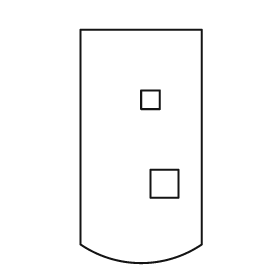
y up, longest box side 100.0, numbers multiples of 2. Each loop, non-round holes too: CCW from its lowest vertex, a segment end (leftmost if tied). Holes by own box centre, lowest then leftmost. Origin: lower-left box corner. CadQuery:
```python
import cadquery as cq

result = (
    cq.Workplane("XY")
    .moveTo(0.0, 8.0)
    .threePointArc((26.0, 0.0), (52.0, 8.0))
    .lineTo(52.0, 100.0)
    .lineTo(0.0, 100.0)
    .close()
    .moveTo(30.0, 28.0)
    .lineTo(42.0, 28.0)
    .lineTo(42.0, 40.0)
    .lineTo(30.0, 40.0)
    .close()
    .moveTo(26.0, 66.0)
    .lineTo(34.0, 66.0)
    .lineTo(34.0, 74.0)
    .lineTo(26.0, 74.0)
    .close()
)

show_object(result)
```